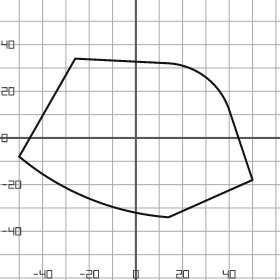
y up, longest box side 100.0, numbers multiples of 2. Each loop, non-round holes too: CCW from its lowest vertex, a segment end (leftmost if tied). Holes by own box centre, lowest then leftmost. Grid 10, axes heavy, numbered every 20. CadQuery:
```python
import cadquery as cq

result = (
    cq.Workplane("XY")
    .moveTo(14.0, -34.0)
    .lineTo(50.0, -18.0)
    .lineTo(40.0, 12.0)
    .threePointArc((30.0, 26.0), (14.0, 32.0))
    .lineTo(-26.0, 34.0)
    .lineTo(-50.0, -8.0)
    .threePointArc((-20.0, -26.0), (14.0, -34.0))
    .close()
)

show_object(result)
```